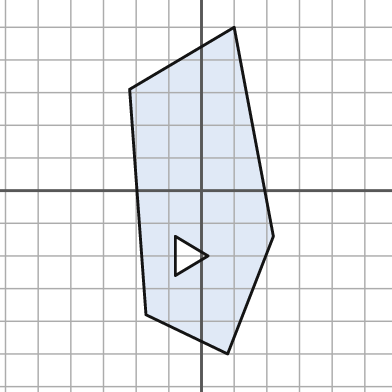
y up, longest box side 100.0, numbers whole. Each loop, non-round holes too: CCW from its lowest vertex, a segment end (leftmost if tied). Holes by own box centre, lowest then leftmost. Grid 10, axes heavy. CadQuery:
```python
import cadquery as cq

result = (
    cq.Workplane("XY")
    .moveTo(8.0, -50.0)
    .lineTo(22.0, -14.0)
    .lineTo(10.0, 50.0)
    .lineTo(-22.0, 31.0)
    .lineTo(-17.0, -38.0)
    .close()
    .moveTo(-8.0, -26.0)
    .lineTo(2.0, -20.0)
    .lineTo(-8.0, -14.0)
    .close()
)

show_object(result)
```